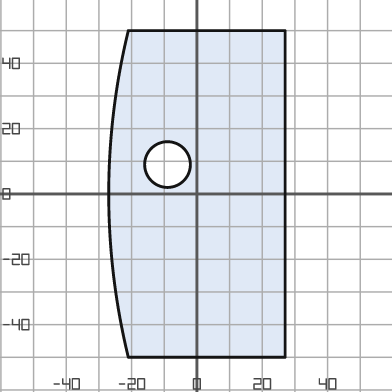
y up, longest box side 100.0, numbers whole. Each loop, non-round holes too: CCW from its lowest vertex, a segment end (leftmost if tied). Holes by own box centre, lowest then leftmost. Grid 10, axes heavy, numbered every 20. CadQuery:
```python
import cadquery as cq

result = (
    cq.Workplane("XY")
    .moveTo(-21.0, -50.0)
    .lineTo(27.0, -50.0)
    .lineTo(27.0, 50.0)
    .lineTo(-21.0, 50.0)
    .threePointArc((-27.0, 0.0), (-21.0, -50.0))
    .close()
    .moveTo(-9.0, 9.0)
    .circle(7.0)
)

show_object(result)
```